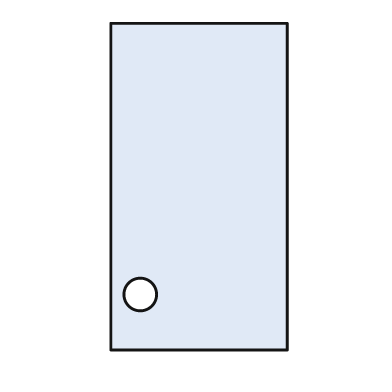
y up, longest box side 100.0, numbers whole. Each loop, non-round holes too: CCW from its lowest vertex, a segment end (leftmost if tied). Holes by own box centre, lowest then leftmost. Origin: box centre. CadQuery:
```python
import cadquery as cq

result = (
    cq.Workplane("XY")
    .moveTo(-27.0, -50.0)
    .lineTo(27.0, -50.0)
    .lineTo(27.0, 50.0)
    .lineTo(-27.0, 50.0)
    .close()
    .moveTo(-18.0, -33.0)
    .circle(5.0)
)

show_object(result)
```